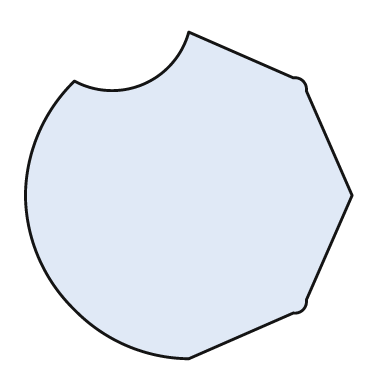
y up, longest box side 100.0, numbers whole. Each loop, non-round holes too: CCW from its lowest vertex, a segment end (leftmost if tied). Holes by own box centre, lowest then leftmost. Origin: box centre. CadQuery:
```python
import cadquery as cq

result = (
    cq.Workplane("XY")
    .moveTo(0.0, -50.0)
    .lineTo(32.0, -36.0)
    .threePointArc((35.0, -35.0), (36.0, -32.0))
    .lineTo(50.0, 0.0)
    .lineTo(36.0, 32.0)
    .threePointArc((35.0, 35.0), (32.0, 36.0))
    .lineTo(0.0, 50.0)
    .threePointArc((-14.0, 34.0), (-35.0, 35.0))
    .threePointArc((-46.0, 19.0), (-50.0, 0.0))
    .threePointArc((-46.0, -19.0), (-35.0, -35.0))
    .threePointArc((-19.0, -46.0), (0.0, -50.0))
    .close()
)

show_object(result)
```